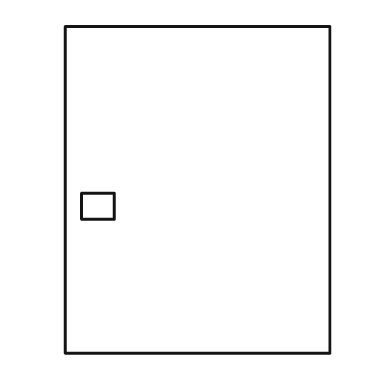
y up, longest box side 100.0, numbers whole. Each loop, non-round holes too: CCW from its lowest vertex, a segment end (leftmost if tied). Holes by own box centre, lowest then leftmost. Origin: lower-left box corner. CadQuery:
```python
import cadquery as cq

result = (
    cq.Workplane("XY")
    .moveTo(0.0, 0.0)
    .lineTo(81.0, 0.0)
    .lineTo(81.0, 100.0)
    .lineTo(0.0, 100.0)
    .close()
    .moveTo(5.0, 41.0)
    .lineTo(15.0, 41.0)
    .lineTo(15.0, 49.0)
    .lineTo(5.0, 49.0)
    .close()
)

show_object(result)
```